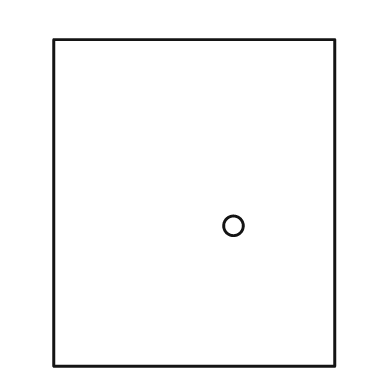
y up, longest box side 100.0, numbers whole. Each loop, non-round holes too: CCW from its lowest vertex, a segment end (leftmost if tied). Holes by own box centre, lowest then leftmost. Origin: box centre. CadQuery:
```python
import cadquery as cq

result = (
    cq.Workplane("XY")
    .moveTo(-43.0, -50.0)
    .lineTo(43.0, -50.0)
    .lineTo(43.0, 50.0)
    .lineTo(-43.0, 50.0)
    .close()
    .moveTo(12.0, -7.0)
    .circle(3.0)
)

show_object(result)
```